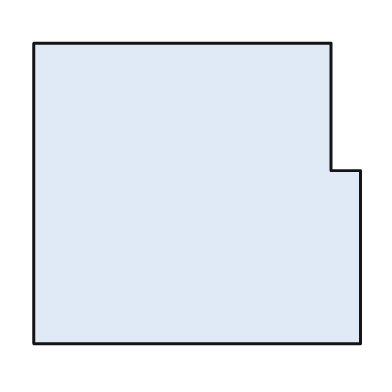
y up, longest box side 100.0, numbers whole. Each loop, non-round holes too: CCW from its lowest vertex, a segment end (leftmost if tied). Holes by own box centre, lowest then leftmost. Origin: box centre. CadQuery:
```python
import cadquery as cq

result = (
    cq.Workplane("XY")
    .moveTo(-50.0, -46.0)
    .lineTo(50.0, -46.0)
    .lineTo(50.0, 7.0)
    .lineTo(41.0, 7.0)
    .lineTo(41.0, 46.0)
    .lineTo(-50.0, 46.0)
    .close()
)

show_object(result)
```